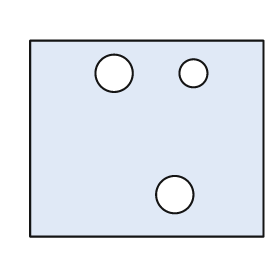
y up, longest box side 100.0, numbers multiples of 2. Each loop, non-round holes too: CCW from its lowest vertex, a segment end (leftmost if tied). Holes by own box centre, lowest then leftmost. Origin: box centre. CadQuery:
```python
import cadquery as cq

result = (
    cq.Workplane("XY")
    .moveTo(-50.0, -42.0)
    .lineTo(50.0, -42.0)
    .lineTo(50.0, 42.0)
    .lineTo(-50.0, 42.0)
    .close()
    .moveTo(12.0, -24.0)
    .circle(8.0)
    .moveTo(-14.0, 28.0)
    .circle(8.0)
    .moveTo(20.0, 28.0)
    .circle(6.0)
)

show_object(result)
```